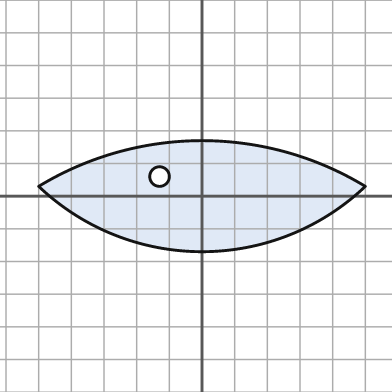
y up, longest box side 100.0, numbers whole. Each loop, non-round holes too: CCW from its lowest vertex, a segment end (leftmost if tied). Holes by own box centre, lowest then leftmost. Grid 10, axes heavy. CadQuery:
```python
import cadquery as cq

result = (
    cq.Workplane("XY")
    .moveTo(-50.0, 3.0)
    .threePointArc((0.0, -17.0), (50.0, 3.0))
    .threePointArc((0.0, 17.0), (-50.0, 3.0))
    .close()
    .moveTo(-13.0, 6.0)
    .circle(3.0)
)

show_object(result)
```